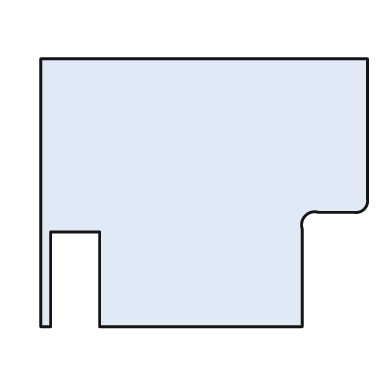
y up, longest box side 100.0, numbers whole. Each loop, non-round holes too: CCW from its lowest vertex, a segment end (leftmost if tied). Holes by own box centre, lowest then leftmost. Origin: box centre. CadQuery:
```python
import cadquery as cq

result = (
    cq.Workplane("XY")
    .moveTo(-50.0, -41.0)
    .lineTo(-47.0, -41.0)
    .lineTo(-47.0, -12.0)
    .lineTo(-32.0, -12.0)
    .lineTo(-32.0, -41.0)
    .lineTo(30.0, -41.0)
    .lineTo(30.0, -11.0)
    .threePointArc((31.0, -7.0), (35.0, -6.0))
    .lineTo(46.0, -6.0)
    .threePointArc((49.0, -5.0), (50.0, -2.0))
    .lineTo(50.0, 41.0)
    .lineTo(-50.0, 41.0)
    .close()
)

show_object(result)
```